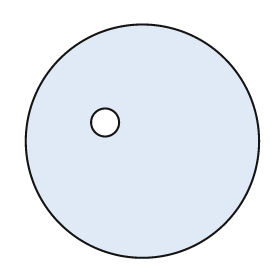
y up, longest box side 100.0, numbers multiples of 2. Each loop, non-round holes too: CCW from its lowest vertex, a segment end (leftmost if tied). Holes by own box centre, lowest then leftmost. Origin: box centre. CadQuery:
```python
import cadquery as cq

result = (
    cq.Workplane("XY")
    .moveTo(0.0, 0.0)
    .circle(50.0)
    .moveTo(-16.0, 8.0)
    .circle(6.0)
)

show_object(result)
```